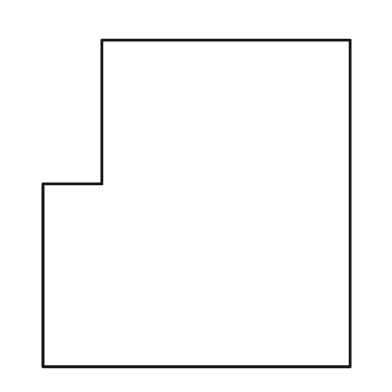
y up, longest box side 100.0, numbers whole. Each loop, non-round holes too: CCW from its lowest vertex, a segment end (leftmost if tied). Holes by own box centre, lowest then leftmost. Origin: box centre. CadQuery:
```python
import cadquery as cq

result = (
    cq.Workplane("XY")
    .moveTo(-47.0, -50.0)
    .lineTo(47.0, -50.0)
    .lineTo(47.0, 50.0)
    .lineTo(-29.0, 50.0)
    .lineTo(-29.0, 6.0)
    .lineTo(-47.0, 6.0)
    .close()
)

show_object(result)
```